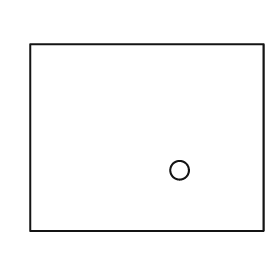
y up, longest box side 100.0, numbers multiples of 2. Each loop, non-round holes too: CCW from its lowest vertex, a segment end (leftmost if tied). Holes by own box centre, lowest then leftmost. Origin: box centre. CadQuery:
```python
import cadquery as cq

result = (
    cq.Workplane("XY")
    .moveTo(-50.0, -40.0)
    .lineTo(50.0, -40.0)
    .lineTo(50.0, 40.0)
    .lineTo(-50.0, 40.0)
    .close()
    .moveTo(14.0, -14.0)
    .circle(4.0)
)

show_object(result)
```